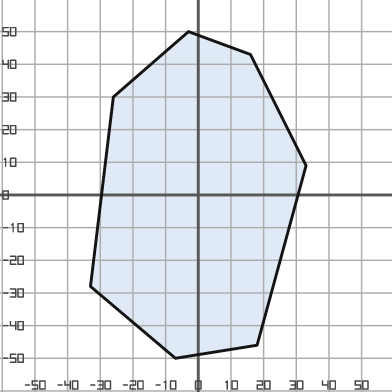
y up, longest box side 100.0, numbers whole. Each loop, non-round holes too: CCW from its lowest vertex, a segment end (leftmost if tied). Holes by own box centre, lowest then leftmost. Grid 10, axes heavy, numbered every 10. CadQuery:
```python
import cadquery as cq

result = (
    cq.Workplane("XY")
    .moveTo(-7.0, -50.0)
    .lineTo(18.0, -46.0)
    .lineTo(33.0, 9.0)
    .lineTo(16.0, 43.0)
    .lineTo(-3.0, 50.0)
    .lineTo(-26.0, 30.0)
    .lineTo(-33.0, -28.0)
    .close()
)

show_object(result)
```